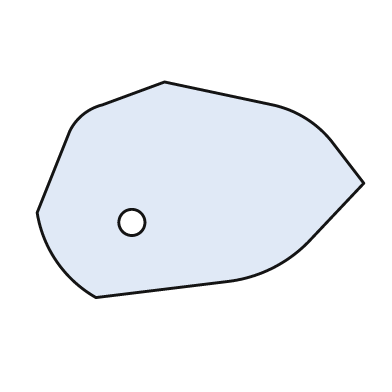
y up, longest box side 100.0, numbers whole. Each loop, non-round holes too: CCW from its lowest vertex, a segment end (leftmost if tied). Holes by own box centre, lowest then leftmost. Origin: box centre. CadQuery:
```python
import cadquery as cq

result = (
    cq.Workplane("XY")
    .moveTo(-32.0, -33.0)
    .lineTo(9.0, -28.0)
    .threePointArc((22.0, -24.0), (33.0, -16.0))
    .lineTo(50.0, 2.0)
    .lineTo(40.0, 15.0)
    .threePointArc((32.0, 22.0), (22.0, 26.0))
    .lineTo(-11.0, 33.0)
    .lineTo(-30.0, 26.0)
    .threePointArc((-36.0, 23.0), (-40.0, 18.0))
    .lineTo(-50.0, -7.0)
    .threePointArc((-44.0, -22.0), (-32.0, -33.0))
    .close()
    .moveTo(-21.0, -10.0)
    .circle(4.0)
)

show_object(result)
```